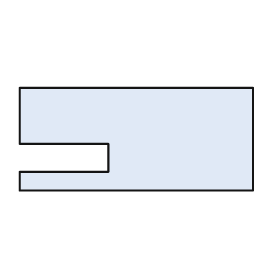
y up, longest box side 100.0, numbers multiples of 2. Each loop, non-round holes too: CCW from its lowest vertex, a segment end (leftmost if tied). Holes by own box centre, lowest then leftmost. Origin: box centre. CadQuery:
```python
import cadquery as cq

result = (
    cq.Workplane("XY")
    .moveTo(-50.0, -22.0)
    .lineTo(50.0, -22.0)
    .lineTo(50.0, 22.0)
    .lineTo(-50.0, 22.0)
    .lineTo(-50.0, -2.0)
    .lineTo(-12.0, -2.0)
    .lineTo(-12.0, -14.0)
    .lineTo(-50.0, -14.0)
    .close()
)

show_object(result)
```